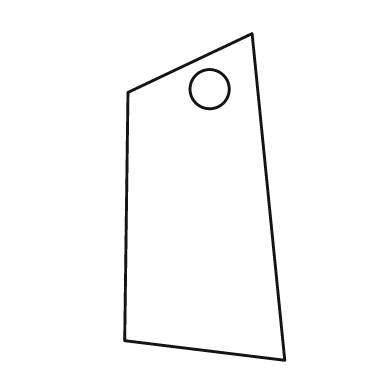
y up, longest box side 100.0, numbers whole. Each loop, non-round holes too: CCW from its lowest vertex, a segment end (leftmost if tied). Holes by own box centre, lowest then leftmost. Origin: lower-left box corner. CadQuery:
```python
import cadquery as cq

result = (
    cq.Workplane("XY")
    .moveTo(49.0, 0.0)
    .lineTo(39.0, 100.0)
    .lineTo(1.0, 82.0)
    .lineTo(0.0, 6.0)
    .close()
    .moveTo(26.0, 83.0)
    .circle(6.0)
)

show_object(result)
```